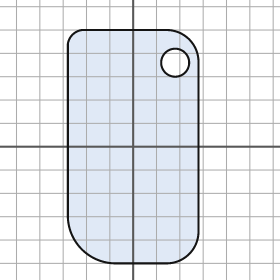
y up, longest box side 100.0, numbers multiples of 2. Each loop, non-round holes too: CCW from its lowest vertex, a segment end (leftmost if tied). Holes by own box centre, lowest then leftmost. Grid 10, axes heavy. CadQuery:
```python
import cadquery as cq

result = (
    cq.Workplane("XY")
    .moveTo(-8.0, -50.0)
    .lineTo(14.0, -50.0)
    .threePointArc((24.0, -46.0), (28.0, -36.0))
    .lineTo(28.0, 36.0)
    .threePointArc((24.0, 46.0), (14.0, 50.0))
    .lineTo(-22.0, 50.0)
    .threePointArc((-26.0, 48.0), (-28.0, 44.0))
    .lineTo(-28.0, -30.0)
    .threePointArc((-22.0, -44.0), (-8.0, -50.0))
    .close()
    .moveTo(18.0, 36.0)
    .circle(6.0)
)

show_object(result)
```